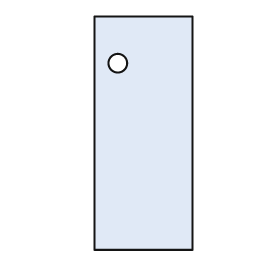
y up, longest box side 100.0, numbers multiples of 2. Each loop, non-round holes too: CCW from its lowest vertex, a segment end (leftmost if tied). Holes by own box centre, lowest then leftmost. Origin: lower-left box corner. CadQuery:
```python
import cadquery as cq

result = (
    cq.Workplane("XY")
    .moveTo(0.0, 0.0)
    .lineTo(42.0, 0.0)
    .lineTo(42.0, 100.0)
    .lineTo(0.0, 100.0)
    .close()
    .moveTo(10.0, 80.0)
    .circle(4.0)
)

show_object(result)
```